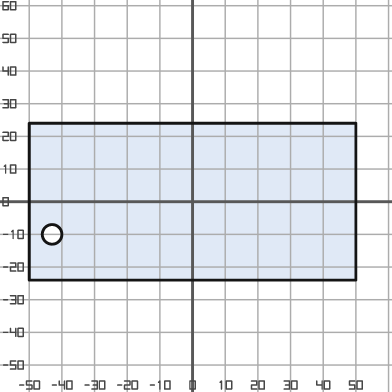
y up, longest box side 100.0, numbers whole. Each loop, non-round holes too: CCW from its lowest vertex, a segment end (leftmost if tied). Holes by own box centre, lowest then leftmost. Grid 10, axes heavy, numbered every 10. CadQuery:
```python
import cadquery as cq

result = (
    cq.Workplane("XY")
    .moveTo(-50.0, -24.0)
    .lineTo(50.0, -24.0)
    .lineTo(50.0, 24.0)
    .lineTo(-50.0, 24.0)
    .close()
    .moveTo(-43.0, -10.0)
    .circle(3.0)
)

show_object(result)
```